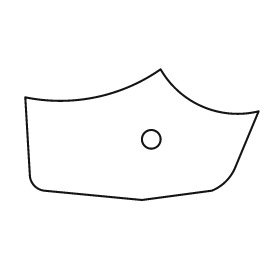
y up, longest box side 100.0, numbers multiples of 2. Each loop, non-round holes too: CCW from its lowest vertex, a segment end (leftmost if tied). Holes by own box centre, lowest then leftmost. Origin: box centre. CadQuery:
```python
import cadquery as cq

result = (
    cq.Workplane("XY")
    .moveTo(0.0, -28.0)
    .lineTo(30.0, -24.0)
    .threePointArc((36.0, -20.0), (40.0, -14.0))
    .lineTo(50.0, 10.0)
    .threePointArc((26.0, 12.0), (8.0, 28.0))
    .threePointArc((-20.0, 16.0), (-50.0, 16.0))
    .lineTo(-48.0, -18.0)
    .threePointArc((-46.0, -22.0), (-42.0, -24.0))
    .close()
    .moveTo(4.0, -2.0)
    .circle(4.0)
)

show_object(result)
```